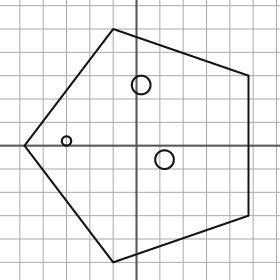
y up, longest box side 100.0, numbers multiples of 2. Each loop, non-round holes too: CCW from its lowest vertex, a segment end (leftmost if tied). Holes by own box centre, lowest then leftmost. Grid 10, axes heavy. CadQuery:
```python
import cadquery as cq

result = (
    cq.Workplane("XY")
    .moveTo(-10.0, -50.0)
    .lineTo(48.0, -30.0)
    .lineTo(48.0, 30.0)
    .lineTo(-10.0, 50.0)
    .lineTo(-48.0, 0.0)
    .close()
    .moveTo(12.0, -6.0)
    .circle(4.0)
    .moveTo(-30.0, 2.0)
    .circle(2.0)
    .moveTo(2.0, 26.0)
    .circle(4.0)
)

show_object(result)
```